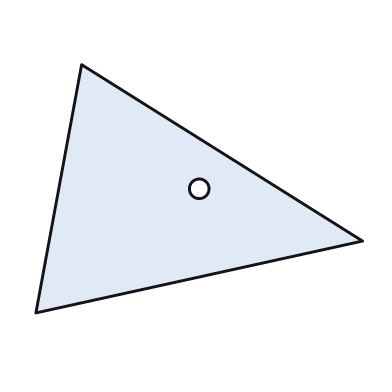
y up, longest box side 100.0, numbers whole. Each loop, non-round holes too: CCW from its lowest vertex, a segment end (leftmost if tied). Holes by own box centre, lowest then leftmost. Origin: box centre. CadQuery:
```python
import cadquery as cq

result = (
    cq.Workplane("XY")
    .moveTo(-50.0, -38.0)
    .lineTo(50.0, -16.0)
    .lineTo(-36.0, 38.0)
    .close()
    .moveTo(0.0, 0.0)
    .circle(3.0)
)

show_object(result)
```